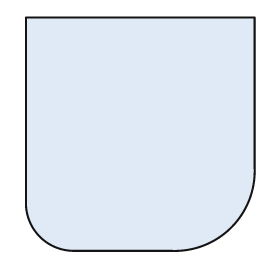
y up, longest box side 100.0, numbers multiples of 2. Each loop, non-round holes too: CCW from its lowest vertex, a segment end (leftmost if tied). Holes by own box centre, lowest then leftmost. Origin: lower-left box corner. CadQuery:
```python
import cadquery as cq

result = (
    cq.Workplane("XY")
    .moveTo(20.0, 0.0)
    .lineTo(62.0, 0.0)
    .threePointArc((88.0, 10.0), (98.0, 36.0))
    .lineTo(98.0, 100.0)
    .lineTo(0.0, 100.0)
    .lineTo(0.0, 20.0)
    .threePointArc((6.0, 6.0), (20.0, 0.0))
    .close()
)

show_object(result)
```